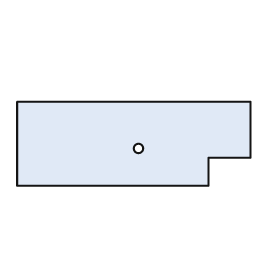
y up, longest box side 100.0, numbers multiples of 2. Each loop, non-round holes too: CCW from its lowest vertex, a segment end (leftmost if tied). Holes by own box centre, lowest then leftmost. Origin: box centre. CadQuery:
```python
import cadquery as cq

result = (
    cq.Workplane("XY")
    .moveTo(-50.0, -18.0)
    .lineTo(32.0, -18.0)
    .lineTo(32.0, -6.0)
    .lineTo(50.0, -6.0)
    .lineTo(50.0, 18.0)
    .lineTo(-50.0, 18.0)
    .close()
    .moveTo(2.0, -2.0)
    .circle(2.0)
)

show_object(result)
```